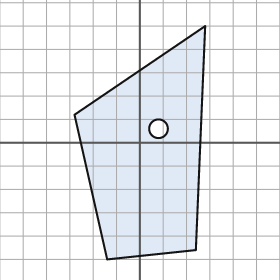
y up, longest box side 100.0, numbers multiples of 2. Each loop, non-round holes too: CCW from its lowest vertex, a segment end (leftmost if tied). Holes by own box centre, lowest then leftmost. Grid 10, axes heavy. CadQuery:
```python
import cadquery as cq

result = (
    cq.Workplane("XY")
    .moveTo(-14.0, -50.0)
    .lineTo(24.0, -46.0)
    .lineTo(28.0, 50.0)
    .lineTo(-28.0, 12.0)
    .close()
    .moveTo(8.0, 6.0)
    .circle(4.0)
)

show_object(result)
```